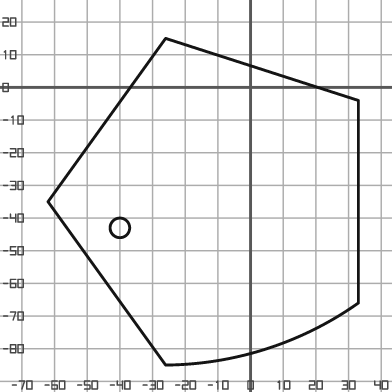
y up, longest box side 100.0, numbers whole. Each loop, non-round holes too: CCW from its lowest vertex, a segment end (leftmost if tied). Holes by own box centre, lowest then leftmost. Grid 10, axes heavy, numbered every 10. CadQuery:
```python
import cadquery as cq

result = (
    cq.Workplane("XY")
    .moveTo(-26.0, -85.0)
    .threePointArc((5.0, -80.0), (33.0, -66.0))
    .lineTo(33.0, -4.0)
    .lineTo(-26.0, 15.0)
    .lineTo(-62.0, -35.0)
    .close()
    .moveTo(-40.0, -43.0)
    .circle(3.0)
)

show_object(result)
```